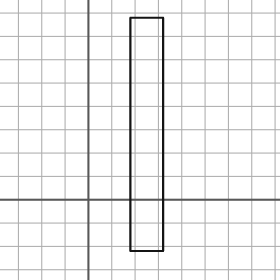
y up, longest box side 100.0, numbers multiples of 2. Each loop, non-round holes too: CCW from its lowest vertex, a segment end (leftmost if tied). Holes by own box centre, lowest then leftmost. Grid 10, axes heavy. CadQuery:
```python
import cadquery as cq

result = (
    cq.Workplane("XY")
    .moveTo(18.0, -22.0)
    .lineTo(32.0, -22.0)
    .lineTo(32.0, 78.0)
    .lineTo(18.0, 78.0)
    .close()
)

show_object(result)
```